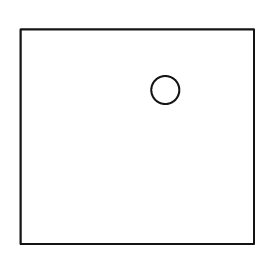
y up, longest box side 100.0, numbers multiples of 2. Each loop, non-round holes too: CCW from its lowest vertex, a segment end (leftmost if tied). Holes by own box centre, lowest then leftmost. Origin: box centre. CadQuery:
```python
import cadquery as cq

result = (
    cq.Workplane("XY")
    .moveTo(-50.0, -46.0)
    .lineTo(50.0, -46.0)
    .lineTo(50.0, 46.0)
    .lineTo(-50.0, 46.0)
    .close()
    .moveTo(12.0, 20.0)
    .circle(6.0)
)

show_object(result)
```